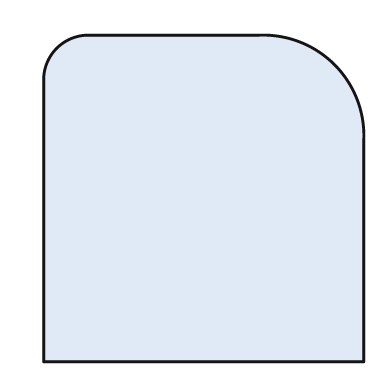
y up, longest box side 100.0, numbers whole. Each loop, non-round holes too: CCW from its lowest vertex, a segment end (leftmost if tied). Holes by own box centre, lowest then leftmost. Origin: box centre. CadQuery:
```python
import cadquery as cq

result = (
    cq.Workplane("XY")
    .moveTo(-49.0, -50.0)
    .lineTo(49.0, -50.0)
    .lineTo(49.0, 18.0)
    .threePointArc((40.0, 41.0), (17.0, 50.0))
    .lineTo(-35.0, 50.0)
    .threePointArc((-45.0, 46.0), (-49.0, 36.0))
    .close()
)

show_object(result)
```